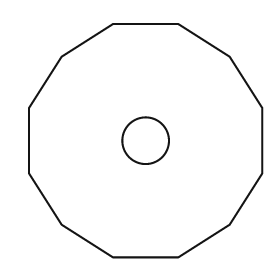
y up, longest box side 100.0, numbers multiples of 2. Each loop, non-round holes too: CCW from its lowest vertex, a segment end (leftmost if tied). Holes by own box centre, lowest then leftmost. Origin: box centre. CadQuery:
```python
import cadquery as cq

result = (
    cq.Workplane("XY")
    .moveTo(-14.0, -50.0)
    .lineTo(14.0, -50.0)
    .lineTo(36.0, -36.0)
    .lineTo(50.0, -14.0)
    .lineTo(50.0, 14.0)
    .lineTo(36.0, 36.0)
    .lineTo(14.0, 50.0)
    .lineTo(-14.0, 50.0)
    .lineTo(-36.0, 36.0)
    .lineTo(-50.0, 14.0)
    .lineTo(-50.0, -14.0)
    .lineTo(-36.0, -36.0)
    .close()
    .moveTo(0.0, 0.0)
    .circle(10.0)
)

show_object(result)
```